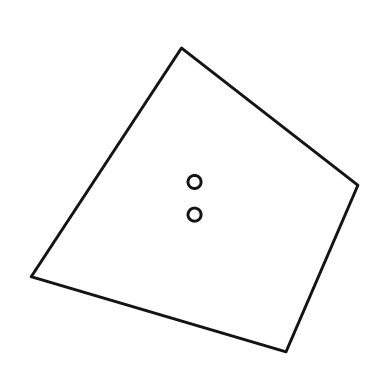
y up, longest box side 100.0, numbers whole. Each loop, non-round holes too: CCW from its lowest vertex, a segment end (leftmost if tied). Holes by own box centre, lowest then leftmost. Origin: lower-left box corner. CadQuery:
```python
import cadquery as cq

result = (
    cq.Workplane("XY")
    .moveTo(78.0, 0.0)
    .lineTo(100.0, 51.0)
    .lineTo(46.0, 93.0)
    .lineTo(0.0, 23.0)
    .close()
    .moveTo(50.0, 42.0)
    .circle(2.0)
    .moveTo(50.0, 52.0)
    .circle(2.0)
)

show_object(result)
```